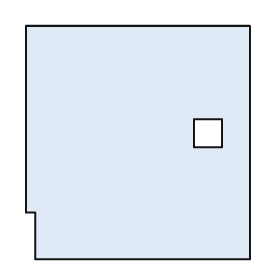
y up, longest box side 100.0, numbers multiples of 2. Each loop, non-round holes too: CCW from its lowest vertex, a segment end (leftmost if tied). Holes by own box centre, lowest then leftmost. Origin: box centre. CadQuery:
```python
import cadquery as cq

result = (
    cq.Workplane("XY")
    .moveTo(-44.0, -50.0)
    .lineTo(48.0, -50.0)
    .lineTo(48.0, 50.0)
    .lineTo(-48.0, 50.0)
    .lineTo(-48.0, -30.0)
    .lineTo(-44.0, -30.0)
    .close()
    .moveTo(24.0, -2.0)
    .lineTo(36.0, -2.0)
    .lineTo(36.0, 10.0)
    .lineTo(24.0, 10.0)
    .close()
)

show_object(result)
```